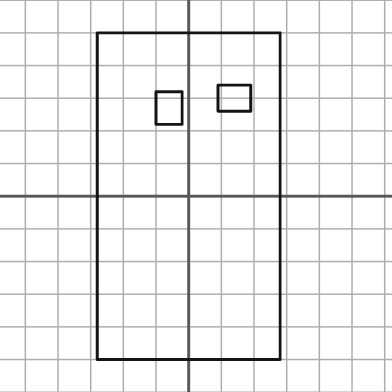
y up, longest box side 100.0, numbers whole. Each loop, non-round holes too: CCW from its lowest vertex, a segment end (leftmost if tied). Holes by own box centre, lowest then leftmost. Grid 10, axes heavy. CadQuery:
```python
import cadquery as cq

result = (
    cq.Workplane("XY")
    .moveTo(-28.0, -50.0)
    .lineTo(28.0, -50.0)
    .lineTo(28.0, 50.0)
    .lineTo(-28.0, 50.0)
    .close()
    .moveTo(-10.0, 22.0)
    .lineTo(-2.0, 22.0)
    .lineTo(-2.0, 32.0)
    .lineTo(-10.0, 32.0)
    .close()
    .moveTo(9.0, 26.0)
    .lineTo(19.0, 26.0)
    .lineTo(19.0, 34.0)
    .lineTo(9.0, 34.0)
    .close()
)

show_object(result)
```